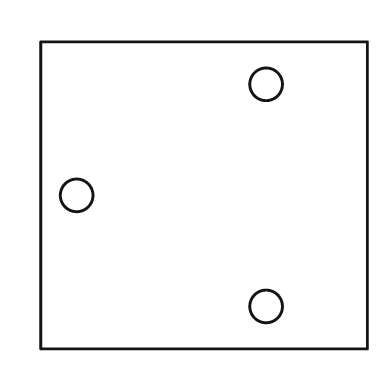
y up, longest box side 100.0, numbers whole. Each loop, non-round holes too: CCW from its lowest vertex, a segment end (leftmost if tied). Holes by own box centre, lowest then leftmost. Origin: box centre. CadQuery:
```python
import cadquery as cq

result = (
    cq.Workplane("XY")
    .moveTo(-50.0, -47.0)
    .lineTo(50.0, -47.0)
    .lineTo(50.0, 47.0)
    .lineTo(-50.0, 47.0)
    .close()
    .moveTo(19.0, -34.0)
    .circle(5.0)
    .moveTo(-39.0, 0.0)
    .circle(5.0)
    .moveTo(19.0, 34.0)
    .circle(5.0)
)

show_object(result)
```